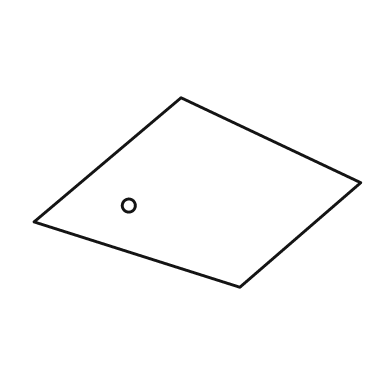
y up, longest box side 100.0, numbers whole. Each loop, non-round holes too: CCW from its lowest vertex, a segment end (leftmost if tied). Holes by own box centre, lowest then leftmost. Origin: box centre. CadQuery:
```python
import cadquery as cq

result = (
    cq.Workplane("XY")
    .moveTo(13.0, -29.0)
    .lineTo(50.0, 3.0)
    .lineTo(-5.0, 29.0)
    .lineTo(-50.0, -9.0)
    .close()
    .moveTo(-21.0, -4.0)
    .circle(2.0)
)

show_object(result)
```